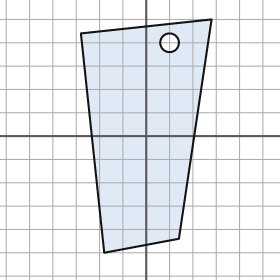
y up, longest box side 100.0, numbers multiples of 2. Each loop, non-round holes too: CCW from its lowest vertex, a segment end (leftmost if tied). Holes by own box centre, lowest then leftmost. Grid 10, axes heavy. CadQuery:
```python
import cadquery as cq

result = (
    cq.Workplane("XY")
    .moveTo(-18.0, -50.0)
    .lineTo(14.0, -44.0)
    .lineTo(28.0, 50.0)
    .lineTo(-28.0, 44.0)
    .close()
    .moveTo(10.0, 40.0)
    .circle(4.0)
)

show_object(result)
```